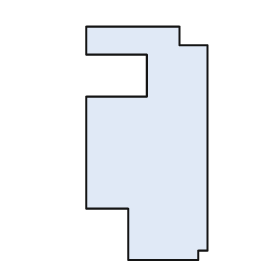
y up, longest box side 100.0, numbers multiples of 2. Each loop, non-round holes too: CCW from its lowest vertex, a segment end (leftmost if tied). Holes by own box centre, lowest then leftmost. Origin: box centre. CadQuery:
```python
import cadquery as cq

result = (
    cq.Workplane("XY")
    .moveTo(-8.0, -50.0)
    .lineTo(22.0, -50.0)
    .lineTo(22.0, -46.0)
    .lineTo(26.0, -46.0)
    .lineTo(26.0, 42.0)
    .lineTo(14.0, 42.0)
    .lineTo(14.0, 50.0)
    .lineTo(-26.0, 50.0)
    .lineTo(-26.0, 38.0)
    .lineTo(0.0, 38.0)
    .lineTo(0.0, 20.0)
    .lineTo(-26.0, 20.0)
    .lineTo(-26.0, -28.0)
    .lineTo(-8.0, -28.0)
    .close()
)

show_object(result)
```